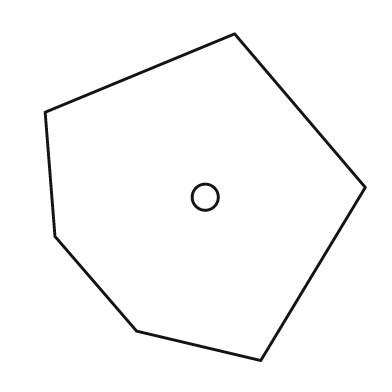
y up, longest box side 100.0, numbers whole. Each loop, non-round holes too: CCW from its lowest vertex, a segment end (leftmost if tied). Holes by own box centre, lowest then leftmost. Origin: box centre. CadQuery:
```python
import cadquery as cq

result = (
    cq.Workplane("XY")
    .moveTo(17.0, -50.0)
    .lineTo(49.0, 3.0)
    .lineTo(9.0, 50.0)
    .lineTo(-49.0, 26.0)
    .lineTo(-46.0, -12.0)
    .lineTo(-21.0, -41.0)
    .close()
    .moveTo(0.0, 0.0)
    .circle(4.0)
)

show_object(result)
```